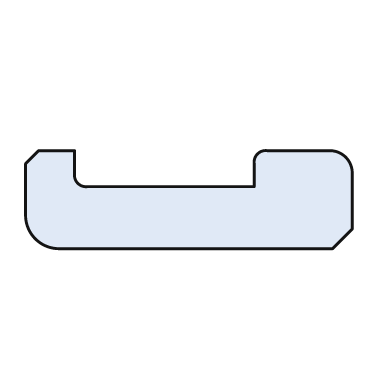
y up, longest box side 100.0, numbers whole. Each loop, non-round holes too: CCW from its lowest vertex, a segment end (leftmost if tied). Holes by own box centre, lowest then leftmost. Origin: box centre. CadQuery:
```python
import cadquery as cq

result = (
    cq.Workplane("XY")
    .moveTo(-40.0, -15.0)
    .lineTo(44.0, -15.0)
    .lineTo(50.0, -9.0)
    .lineTo(50.0, 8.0)
    .threePointArc((48.0, 13.0), (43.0, 15.0))
    .lineTo(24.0, 15.0)
    .threePointArc((21.0, 14.0), (20.0, 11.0))
    .lineTo(20.0, 4.0)
    .lineTo(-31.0, 4.0)
    .threePointArc((-34.0, 5.0), (-35.0, 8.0))
    .lineTo(-35.0, 15.0)
    .lineTo(-46.0, 15.0)
    .lineTo(-50.0, 11.0)
    .lineTo(-50.0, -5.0)
    .threePointArc((-47.0, -12.0), (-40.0, -15.0))
    .close()
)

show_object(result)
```